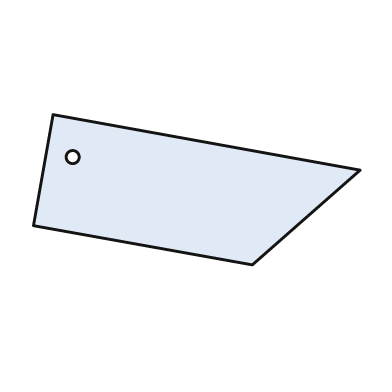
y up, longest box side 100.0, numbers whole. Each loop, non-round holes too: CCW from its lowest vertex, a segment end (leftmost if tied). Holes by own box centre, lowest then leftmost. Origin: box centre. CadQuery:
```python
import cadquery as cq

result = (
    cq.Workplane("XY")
    .moveTo(17.0, -23.0)
    .lineTo(50.0, 6.0)
    .lineTo(-44.0, 23.0)
    .lineTo(-50.0, -11.0)
    .close()
    .moveTo(-38.0, 10.0)
    .circle(2.0)
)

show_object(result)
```